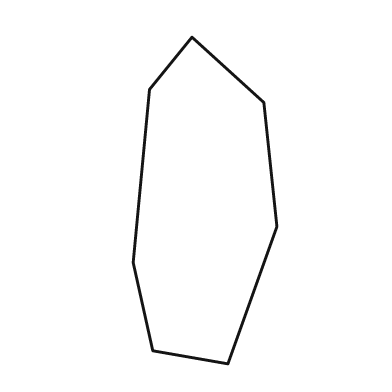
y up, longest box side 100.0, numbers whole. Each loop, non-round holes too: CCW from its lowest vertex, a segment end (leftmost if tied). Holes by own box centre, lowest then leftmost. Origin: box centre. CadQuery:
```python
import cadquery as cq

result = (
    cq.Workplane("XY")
    .moveTo(7.0, -50.0)
    .lineTo(22.0, -8.0)
    .lineTo(18.0, 30.0)
    .lineTo(-4.0, 50.0)
    .lineTo(-17.0, 34.0)
    .lineTo(-22.0, -19.0)
    .lineTo(-16.0, -46.0)
    .close()
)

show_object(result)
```